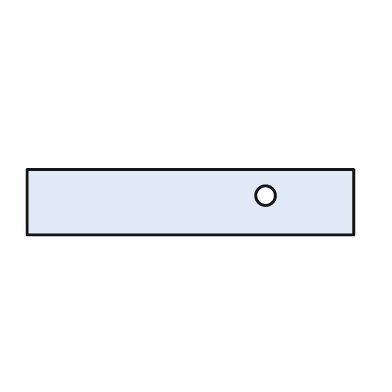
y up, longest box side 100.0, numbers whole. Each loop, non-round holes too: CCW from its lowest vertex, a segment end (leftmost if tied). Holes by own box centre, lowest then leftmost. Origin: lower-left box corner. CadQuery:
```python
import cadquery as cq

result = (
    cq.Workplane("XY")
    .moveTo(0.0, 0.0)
    .lineTo(100.0, 0.0)
    .lineTo(100.0, 20.0)
    .lineTo(0.0, 20.0)
    .close()
    .moveTo(73.0, 12.0)
    .circle(3.0)
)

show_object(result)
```